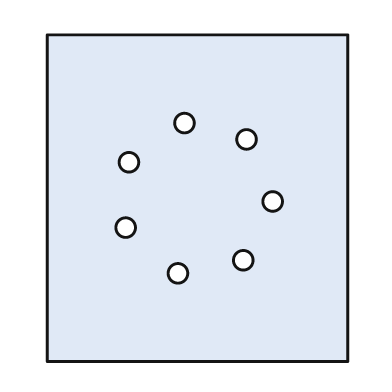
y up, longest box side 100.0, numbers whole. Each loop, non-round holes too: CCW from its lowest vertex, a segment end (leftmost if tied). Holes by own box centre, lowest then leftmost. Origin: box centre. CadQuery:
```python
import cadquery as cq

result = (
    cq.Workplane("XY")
    .moveTo(-46.0, -50.0)
    .lineTo(46.0, -50.0)
    .lineTo(46.0, 50.0)
    .lineTo(-46.0, 50.0)
    .close()
    .moveTo(-6.0, -23.0)
    .circle(3.0)
    .moveTo(14.0, -19.0)
    .circle(3.0)
    .moveTo(-22.0, -9.0)
    .circle(3.0)
    .moveTo(23.0, -1.0)
    .circle(3.0)
    .moveTo(-21.0, 11.0)
    .circle(3.0)
    .moveTo(15.0, 18.0)
    .circle(3.0)
    .moveTo(-4.0, 23.0)
    .circle(3.0)
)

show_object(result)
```